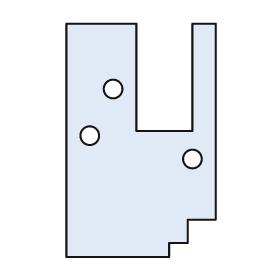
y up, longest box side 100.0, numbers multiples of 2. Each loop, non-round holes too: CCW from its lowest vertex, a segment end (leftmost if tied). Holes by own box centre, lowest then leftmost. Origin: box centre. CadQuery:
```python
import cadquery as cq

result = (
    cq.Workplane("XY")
    .moveTo(-32.0, -50.0)
    .lineTo(12.0, -50.0)
    .lineTo(12.0, -44.0)
    .lineTo(20.0, -44.0)
    .lineTo(20.0, -34.0)
    .lineTo(32.0, -34.0)
    .lineTo(32.0, 50.0)
    .lineTo(22.0, 50.0)
    .lineTo(22.0, 4.0)
    .lineTo(-2.0, 4.0)
    .lineTo(-2.0, 50.0)
    .lineTo(-32.0, 50.0)
    .close()
    .moveTo(22.0, -8.0)
    .circle(4.0)
    .moveTo(-22.0, 2.0)
    .circle(4.0)
    .moveTo(-12.0, 22.0)
    .circle(4.0)
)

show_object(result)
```